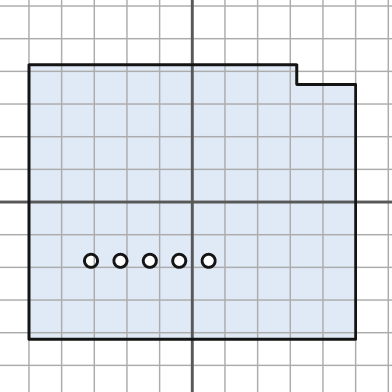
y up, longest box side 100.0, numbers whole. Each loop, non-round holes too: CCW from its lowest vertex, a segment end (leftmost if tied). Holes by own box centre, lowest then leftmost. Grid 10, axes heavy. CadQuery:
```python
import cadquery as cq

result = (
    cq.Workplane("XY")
    .moveTo(-50.0, -42.0)
    .lineTo(50.0, -42.0)
    .lineTo(50.0, 36.0)
    .lineTo(32.0, 36.0)
    .lineTo(32.0, 42.0)
    .lineTo(-50.0, 42.0)
    .close()
    .moveTo(-31.0, -18.0)
    .circle(2.0)
    .moveTo(-22.0, -18.0)
    .circle(2.0)
    .moveTo(-13.0, -18.0)
    .circle(2.0)
    .moveTo(-4.0, -18.0)
    .circle(2.0)
    .moveTo(5.0, -18.0)
    .circle(2.0)
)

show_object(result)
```